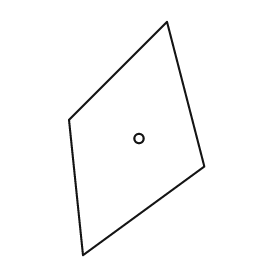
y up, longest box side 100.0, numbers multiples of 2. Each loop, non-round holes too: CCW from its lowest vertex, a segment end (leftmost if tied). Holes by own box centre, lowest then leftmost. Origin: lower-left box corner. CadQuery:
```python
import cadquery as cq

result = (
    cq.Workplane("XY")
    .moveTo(6.0, 0.0)
    .lineTo(58.0, 38.0)
    .lineTo(42.0, 100.0)
    .lineTo(0.0, 58.0)
    .close()
    .moveTo(30.0, 50.0)
    .circle(2.0)
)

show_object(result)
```